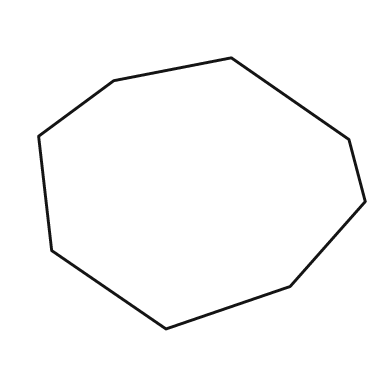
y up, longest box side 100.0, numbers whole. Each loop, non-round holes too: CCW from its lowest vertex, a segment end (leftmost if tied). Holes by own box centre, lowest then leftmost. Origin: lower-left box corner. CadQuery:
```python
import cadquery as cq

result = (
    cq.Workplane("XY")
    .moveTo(39.0, 0.0)
    .lineTo(77.0, 13.0)
    .lineTo(100.0, 39.0)
    .lineTo(95.0, 58.0)
    .lineTo(59.0, 83.0)
    .lineTo(23.0, 76.0)
    .lineTo(0.0, 59.0)
    .lineTo(4.0, 24.0)
    .close()
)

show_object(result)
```